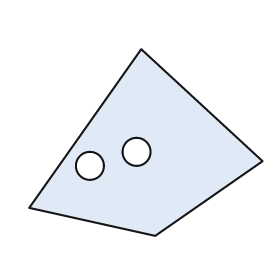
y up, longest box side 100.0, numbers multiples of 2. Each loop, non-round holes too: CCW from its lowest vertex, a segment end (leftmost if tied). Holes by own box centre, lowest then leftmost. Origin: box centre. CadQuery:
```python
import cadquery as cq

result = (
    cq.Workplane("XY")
    .moveTo(4.0, -40.0)
    .lineTo(50.0, -8.0)
    .lineTo(-2.0, 40.0)
    .lineTo(-50.0, -28.0)
    .close()
    .moveTo(-24.0, -10.0)
    .circle(6.0)
    .moveTo(-4.0, -4.0)
    .circle(6.0)
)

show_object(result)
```